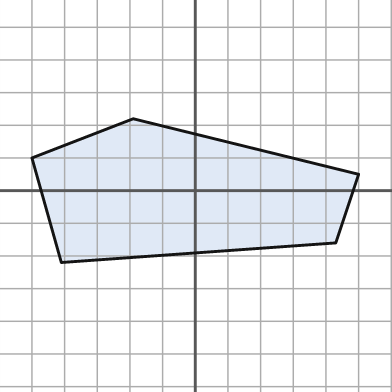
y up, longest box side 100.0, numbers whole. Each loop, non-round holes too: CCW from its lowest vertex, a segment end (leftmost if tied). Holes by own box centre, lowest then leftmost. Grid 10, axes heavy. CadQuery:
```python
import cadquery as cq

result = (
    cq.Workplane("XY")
    .moveTo(-41.0, -22.0)
    .lineTo(43.0, -16.0)
    .lineTo(50.0, 5.0)
    .lineTo(-19.0, 22.0)
    .lineTo(-50.0, 10.0)
    .close()
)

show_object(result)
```